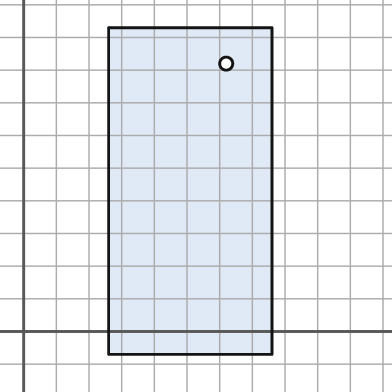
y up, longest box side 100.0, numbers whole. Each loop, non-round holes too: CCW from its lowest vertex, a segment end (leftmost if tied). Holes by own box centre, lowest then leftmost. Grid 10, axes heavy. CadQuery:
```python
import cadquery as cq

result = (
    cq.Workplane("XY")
    .moveTo(26.0, -7.0)
    .lineTo(76.0, -7.0)
    .lineTo(76.0, 93.0)
    .lineTo(26.0, 93.0)
    .close()
    .moveTo(62.0, 82.0)
    .circle(2.0)
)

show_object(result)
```